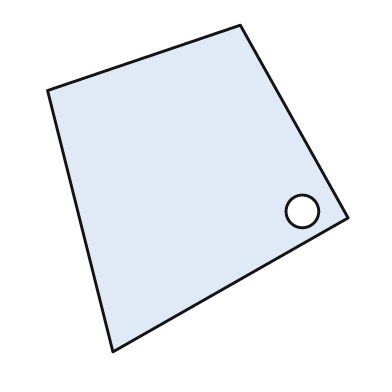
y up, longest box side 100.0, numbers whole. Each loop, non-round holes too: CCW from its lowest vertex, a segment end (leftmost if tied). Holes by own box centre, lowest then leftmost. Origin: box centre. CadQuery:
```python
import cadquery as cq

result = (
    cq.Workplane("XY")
    .moveTo(-26.0, -50.0)
    .lineTo(46.0, -9.0)
    .lineTo(13.0, 50.0)
    .lineTo(-46.0, 30.0)
    .close()
    .moveTo(32.0, -7.0)
    .circle(5.0)
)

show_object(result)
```